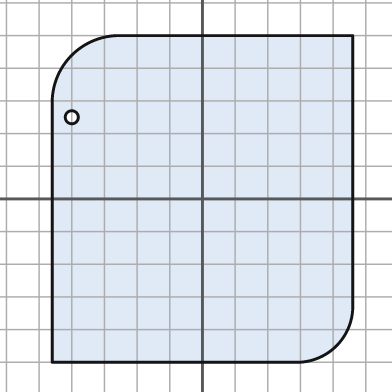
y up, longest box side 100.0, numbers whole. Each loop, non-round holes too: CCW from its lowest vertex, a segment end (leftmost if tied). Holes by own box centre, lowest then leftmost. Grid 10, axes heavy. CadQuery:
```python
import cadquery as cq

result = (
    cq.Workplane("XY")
    .moveTo(-46.0, -50.0)
    .lineTo(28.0, -50.0)
    .threePointArc((41.0, -45.0), (46.0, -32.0))
    .lineTo(46.0, 50.0)
    .lineTo(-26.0, 50.0)
    .threePointArc((-40.0, 44.0), (-46.0, 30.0))
    .close()
    .moveTo(-40.0, 25.0)
    .circle(2.0)
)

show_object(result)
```